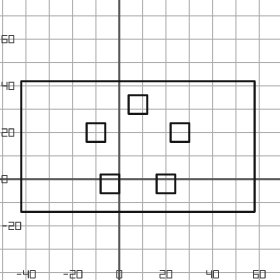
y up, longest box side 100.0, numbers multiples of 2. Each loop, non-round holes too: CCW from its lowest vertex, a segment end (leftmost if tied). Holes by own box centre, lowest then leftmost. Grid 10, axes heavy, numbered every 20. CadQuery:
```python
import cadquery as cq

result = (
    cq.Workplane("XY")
    .moveTo(-42.0, -14.0)
    .lineTo(58.0, -14.0)
    .lineTo(58.0, 42.0)
    .lineTo(-42.0, 42.0)
    .close()
    .moveTo(-8.0, -6.0)
    .lineTo(0.0, -6.0)
    .lineTo(0.0, 2.0)
    .lineTo(-8.0, 2.0)
    .close()
    .moveTo(16.0, -6.0)
    .lineTo(24.0, -6.0)
    .lineTo(24.0, 2.0)
    .lineTo(16.0, 2.0)
    .close()
    .moveTo(-14.0, 16.0)
    .lineTo(-6.0, 16.0)
    .lineTo(-6.0, 24.0)
    .lineTo(-14.0, 24.0)
    .close()
    .moveTo(22.0, 16.0)
    .lineTo(30.0, 16.0)
    .lineTo(30.0, 24.0)
    .lineTo(22.0, 24.0)
    .close()
    .moveTo(4.0, 28.0)
    .lineTo(12.0, 28.0)
    .lineTo(12.0, 36.0)
    .lineTo(4.0, 36.0)
    .close()
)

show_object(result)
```